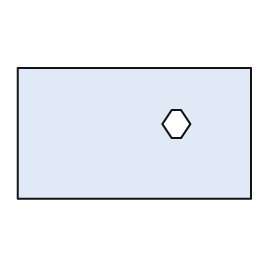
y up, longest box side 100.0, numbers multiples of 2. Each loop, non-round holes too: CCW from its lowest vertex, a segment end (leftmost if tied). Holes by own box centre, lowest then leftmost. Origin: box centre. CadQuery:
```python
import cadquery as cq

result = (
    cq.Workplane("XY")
    .moveTo(-50.0, -28.0)
    .lineTo(50.0, -28.0)
    .lineTo(50.0, 28.0)
    .lineTo(-50.0, 28.0)
    .close()
    .moveTo(16.0, -2.0)
    .lineTo(20.0, -2.0)
    .lineTo(24.0, 4.0)
    .lineTo(20.0, 10.0)
    .lineTo(16.0, 10.0)
    .lineTo(12.0, 4.0)
    .close()
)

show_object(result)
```